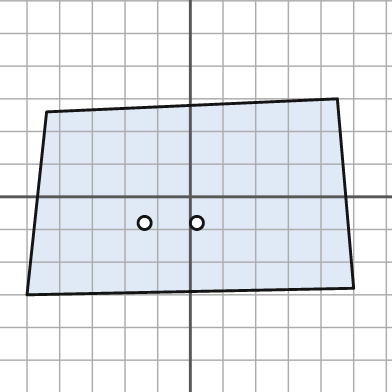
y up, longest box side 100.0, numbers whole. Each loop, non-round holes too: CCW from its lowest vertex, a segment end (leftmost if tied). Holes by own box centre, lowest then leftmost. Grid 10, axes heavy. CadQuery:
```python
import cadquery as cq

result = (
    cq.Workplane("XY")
    .moveTo(-50.0, -30.0)
    .lineTo(50.0, -28.0)
    .lineTo(45.0, 30.0)
    .lineTo(-44.0, 26.0)
    .close()
    .moveTo(-14.0, -8.0)
    .circle(2.0)
    .moveTo(2.0, -8.0)
    .circle(2.0)
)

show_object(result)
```